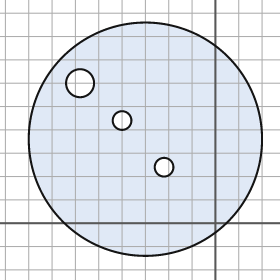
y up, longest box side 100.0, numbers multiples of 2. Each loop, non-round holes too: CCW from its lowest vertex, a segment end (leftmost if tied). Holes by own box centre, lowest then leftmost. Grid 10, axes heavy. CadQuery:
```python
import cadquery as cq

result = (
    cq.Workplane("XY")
    .moveTo(-30.0, 36.0)
    .circle(50.0)
    .moveTo(-22.0, 24.0)
    .circle(4.0)
    .moveTo(-40.0, 44.0)
    .circle(4.0)
    .moveTo(-58.0, 60.0)
    .circle(6.0)
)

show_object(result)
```